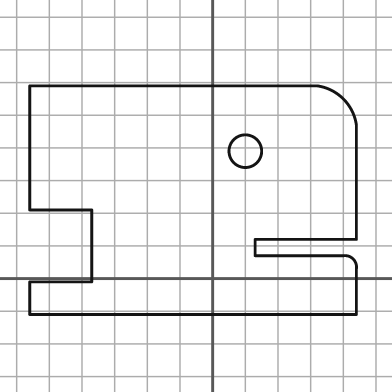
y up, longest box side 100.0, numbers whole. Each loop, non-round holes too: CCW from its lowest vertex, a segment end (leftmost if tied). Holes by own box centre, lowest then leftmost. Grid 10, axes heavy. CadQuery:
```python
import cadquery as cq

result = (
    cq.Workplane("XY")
    .moveTo(-56.0, -11.0)
    .lineTo(44.0, -11.0)
    .lineTo(44.0, 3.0)
    .threePointArc((43.0, 6.0), (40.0, 7.0))
    .lineTo(13.0, 7.0)
    .lineTo(13.0, 12.0)
    .lineTo(44.0, 12.0)
    .lineTo(44.0, 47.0)
    .threePointArc((40.0, 55.0), (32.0, 59.0))
    .lineTo(-56.0, 59.0)
    .lineTo(-56.0, 21.0)
    .lineTo(-37.0, 21.0)
    .lineTo(-37.0, -1.0)
    .lineTo(-56.0, -1.0)
    .close()
    .moveTo(10.0, 39.0)
    .circle(5.0)
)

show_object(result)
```